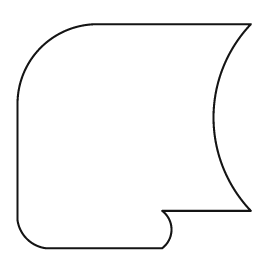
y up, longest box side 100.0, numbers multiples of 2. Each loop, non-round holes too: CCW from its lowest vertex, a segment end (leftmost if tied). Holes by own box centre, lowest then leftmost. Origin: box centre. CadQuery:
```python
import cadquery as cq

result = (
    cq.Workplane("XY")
    .moveTo(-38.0, -48.0)
    .lineTo(12.0, -48.0)
    .threePointArc((16.0, -40.0), (12.0, -32.0))
    .lineTo(50.0, -32.0)
    .threePointArc((34.0, 8.0), (50.0, 48.0))
    .lineTo(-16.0, 48.0)
    .threePointArc((-40.0, 38.0), (-50.0, 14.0))
    .lineTo(-50.0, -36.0)
    .threePointArc((-46.0, -44.0), (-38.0, -48.0))
    .close()
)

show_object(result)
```